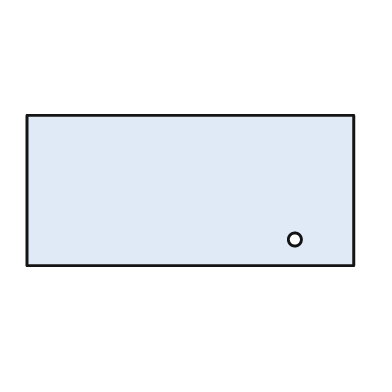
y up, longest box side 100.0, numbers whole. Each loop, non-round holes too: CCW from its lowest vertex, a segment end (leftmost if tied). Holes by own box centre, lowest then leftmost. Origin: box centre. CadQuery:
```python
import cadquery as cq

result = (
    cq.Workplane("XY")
    .moveTo(-50.0, -23.0)
    .lineTo(50.0, -23.0)
    .lineTo(50.0, 23.0)
    .lineTo(-50.0, 23.0)
    .close()
    .moveTo(32.0, -15.0)
    .circle(2.0)
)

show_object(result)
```